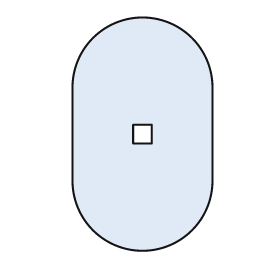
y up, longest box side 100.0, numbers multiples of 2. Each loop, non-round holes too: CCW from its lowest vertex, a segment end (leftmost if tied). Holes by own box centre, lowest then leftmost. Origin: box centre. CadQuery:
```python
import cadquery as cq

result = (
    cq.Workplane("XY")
    .moveTo(-30.0, -20.0)
    .threePointArc((0.0, -50.0), (30.0, -20.0))
    .lineTo(30.0, 20.0)
    .threePointArc((0.0, 50.0), (-30.0, 20.0))
    .close()
    .moveTo(-4.0, -4.0)
    .lineTo(4.0, -4.0)
    .lineTo(4.0, 4.0)
    .lineTo(-4.0, 4.0)
    .close()
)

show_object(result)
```